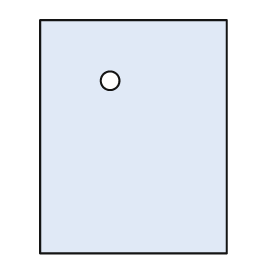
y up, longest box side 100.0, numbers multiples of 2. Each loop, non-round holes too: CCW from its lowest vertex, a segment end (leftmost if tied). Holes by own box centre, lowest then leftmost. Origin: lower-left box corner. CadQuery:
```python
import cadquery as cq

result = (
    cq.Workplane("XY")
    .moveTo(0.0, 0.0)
    .lineTo(80.0, 0.0)
    .lineTo(80.0, 100.0)
    .lineTo(0.0, 100.0)
    .close()
    .moveTo(30.0, 74.0)
    .circle(4.0)
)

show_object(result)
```